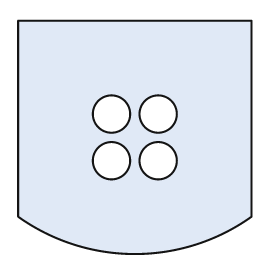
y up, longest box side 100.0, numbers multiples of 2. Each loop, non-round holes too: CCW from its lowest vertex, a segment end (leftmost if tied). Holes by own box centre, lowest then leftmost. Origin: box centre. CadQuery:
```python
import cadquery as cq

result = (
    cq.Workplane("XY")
    .moveTo(-50.0, -34.0)
    .threePointArc((0.0, -50.0), (50.0, -34.0))
    .lineTo(50.0, 50.0)
    .lineTo(-50.0, 50.0)
    .close()
    .moveTo(-10.0, -10.0)
    .circle(8.0)
    .moveTo(10.0, -10.0)
    .circle(8.0)
    .moveTo(-10.0, 10.0)
    .circle(8.0)
    .moveTo(10.0, 10.0)
    .circle(8.0)
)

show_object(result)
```